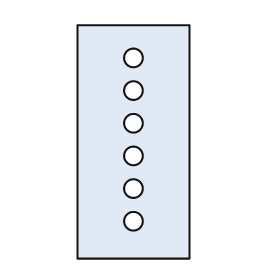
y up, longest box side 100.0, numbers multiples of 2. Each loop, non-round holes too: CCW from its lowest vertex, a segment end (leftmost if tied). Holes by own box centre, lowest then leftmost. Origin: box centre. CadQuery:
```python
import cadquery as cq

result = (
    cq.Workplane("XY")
    .moveTo(-24.0, -50.0)
    .lineTo(24.0, -50.0)
    .lineTo(24.0, 50.0)
    .lineTo(-24.0, 50.0)
    .close()
    .moveTo(0.0, -34.0)
    .circle(4.0)
    .moveTo(0.0, -20.0)
    .circle(4.0)
    .moveTo(0.0, -6.0)
    .circle(4.0)
    .moveTo(0.0, 8.0)
    .circle(4.0)
    .moveTo(0.0, 22.0)
    .circle(4.0)
    .moveTo(0.0, 36.0)
    .circle(4.0)
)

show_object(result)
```